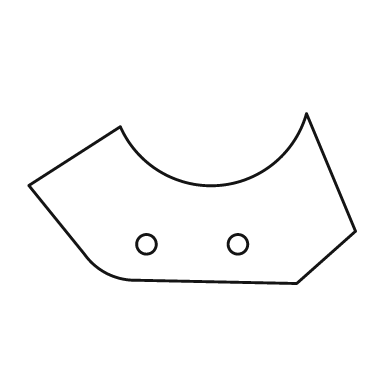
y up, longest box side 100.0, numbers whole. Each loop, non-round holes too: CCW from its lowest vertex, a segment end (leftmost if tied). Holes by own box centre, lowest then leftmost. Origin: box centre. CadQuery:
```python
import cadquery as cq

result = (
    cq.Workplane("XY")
    .moveTo(32.0, -26.0)
    .lineTo(50.0, -10.0)
    .lineTo(35.0, 26.0)
    .threePointArc((8.0, 4.0), (-22.0, 22.0))
    .lineTo(-50.0, 4.0)
    .lineTo(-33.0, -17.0)
    .threePointArc((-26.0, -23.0), (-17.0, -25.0))
    .close()
    .moveTo(-14.0, -14.0)
    .circle(3.0)
    .moveTo(14.0, -14.0)
    .circle(3.0)
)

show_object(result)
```